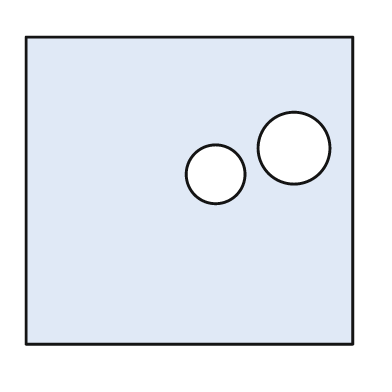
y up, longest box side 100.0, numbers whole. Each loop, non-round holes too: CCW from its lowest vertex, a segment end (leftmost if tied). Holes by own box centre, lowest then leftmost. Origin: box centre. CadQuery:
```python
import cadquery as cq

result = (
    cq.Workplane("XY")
    .moveTo(-50.0, -47.0)
    .lineTo(50.0, -47.0)
    .lineTo(50.0, 47.0)
    .lineTo(-50.0, 47.0)
    .close()
    .moveTo(8.0, 5.0)
    .circle(9.0)
    .moveTo(32.0, 13.0)
    .circle(11.0)
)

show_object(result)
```